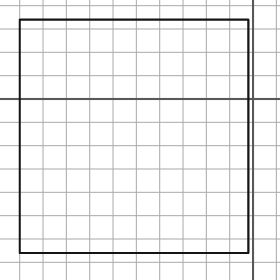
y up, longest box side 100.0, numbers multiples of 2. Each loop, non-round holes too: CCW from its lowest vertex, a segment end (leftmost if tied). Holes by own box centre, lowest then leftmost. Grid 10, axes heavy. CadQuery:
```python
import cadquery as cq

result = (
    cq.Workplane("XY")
    .moveTo(-100.0, -66.0)
    .lineTo(-2.0, -66.0)
    .lineTo(-2.0, 34.0)
    .lineTo(-100.0, 34.0)
    .close()
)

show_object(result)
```